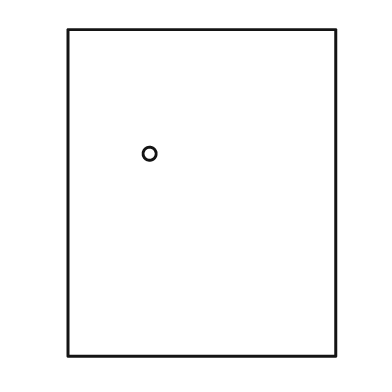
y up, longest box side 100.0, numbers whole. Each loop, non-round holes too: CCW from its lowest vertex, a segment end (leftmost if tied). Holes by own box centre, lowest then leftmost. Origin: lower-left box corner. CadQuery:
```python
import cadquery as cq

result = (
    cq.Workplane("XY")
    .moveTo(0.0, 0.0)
    .lineTo(82.0, 0.0)
    .lineTo(82.0, 100.0)
    .lineTo(0.0, 100.0)
    .close()
    .moveTo(25.0, 62.0)
    .circle(2.0)
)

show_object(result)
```